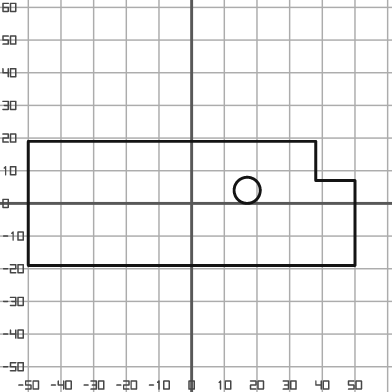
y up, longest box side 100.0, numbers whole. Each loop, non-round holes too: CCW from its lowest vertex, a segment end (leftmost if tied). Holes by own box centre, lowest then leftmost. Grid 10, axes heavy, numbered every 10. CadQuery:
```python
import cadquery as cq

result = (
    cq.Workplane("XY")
    .moveTo(-50.0, -19.0)
    .lineTo(50.0, -19.0)
    .lineTo(50.0, 7.0)
    .lineTo(38.0, 7.0)
    .lineTo(38.0, 19.0)
    .lineTo(-50.0, 19.0)
    .close()
    .moveTo(17.0, 4.0)
    .circle(4.0)
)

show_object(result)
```